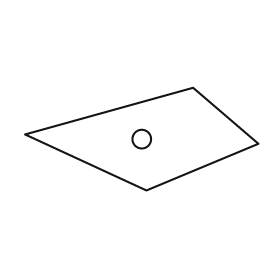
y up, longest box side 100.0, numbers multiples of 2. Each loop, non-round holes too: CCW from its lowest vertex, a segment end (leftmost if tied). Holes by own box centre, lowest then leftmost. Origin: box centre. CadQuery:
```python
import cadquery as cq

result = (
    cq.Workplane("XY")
    .moveTo(2.0, -22.0)
    .lineTo(50.0, -2.0)
    .lineTo(22.0, 22.0)
    .lineTo(-50.0, 2.0)
    .close()
    .moveTo(0.0, 0.0)
    .circle(4.0)
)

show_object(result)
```